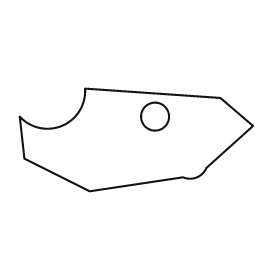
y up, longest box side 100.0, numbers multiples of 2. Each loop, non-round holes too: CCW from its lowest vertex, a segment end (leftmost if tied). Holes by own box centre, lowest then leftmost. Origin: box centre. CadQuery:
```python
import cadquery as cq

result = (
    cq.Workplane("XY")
    .moveTo(-20.0, -22.0)
    .lineTo(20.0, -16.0)
    .threePointArc((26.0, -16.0), (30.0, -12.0))
    .lineTo(50.0, 6.0)
    .lineTo(36.0, 18.0)
    .lineTo(-22.0, 22.0)
    .threePointArc((-32.0, 6.0), (-50.0, 10.0))
    .lineTo(-48.0, -8.0)
    .close()
    .moveTo(8.0, 10.0)
    .circle(6.0)
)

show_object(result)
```